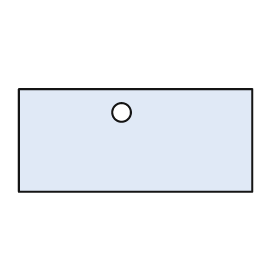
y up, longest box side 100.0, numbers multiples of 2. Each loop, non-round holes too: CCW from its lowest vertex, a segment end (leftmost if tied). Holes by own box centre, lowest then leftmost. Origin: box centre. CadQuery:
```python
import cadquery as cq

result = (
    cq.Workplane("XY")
    .moveTo(-50.0, -22.0)
    .lineTo(50.0, -22.0)
    .lineTo(50.0, 22.0)
    .lineTo(-50.0, 22.0)
    .close()
    .moveTo(-6.0, 12.0)
    .circle(4.0)
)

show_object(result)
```